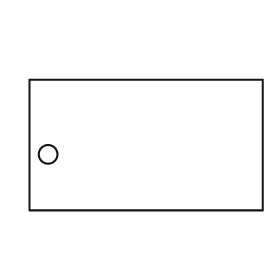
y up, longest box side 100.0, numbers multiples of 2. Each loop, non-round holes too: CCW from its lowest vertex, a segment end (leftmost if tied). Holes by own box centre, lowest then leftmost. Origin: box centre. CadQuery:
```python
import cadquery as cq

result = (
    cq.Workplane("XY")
    .moveTo(-50.0, -28.0)
    .lineTo(50.0, -28.0)
    .lineTo(50.0, 28.0)
    .lineTo(-50.0, 28.0)
    .close()
    .moveTo(-42.0, -4.0)
    .circle(4.0)
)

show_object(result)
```